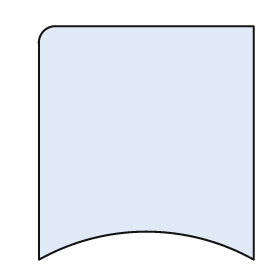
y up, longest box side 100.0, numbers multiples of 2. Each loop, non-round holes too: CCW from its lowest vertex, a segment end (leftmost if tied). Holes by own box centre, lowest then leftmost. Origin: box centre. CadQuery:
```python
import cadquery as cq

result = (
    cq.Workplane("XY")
    .moveTo(-46.0, -50.0)
    .threePointArc((0.0, -38.0), (46.0, -50.0))
    .lineTo(46.0, 50.0)
    .lineTo(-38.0, 50.0)
    .threePointArc((-44.0, 48.0), (-46.0, 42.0))
    .close()
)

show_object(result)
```